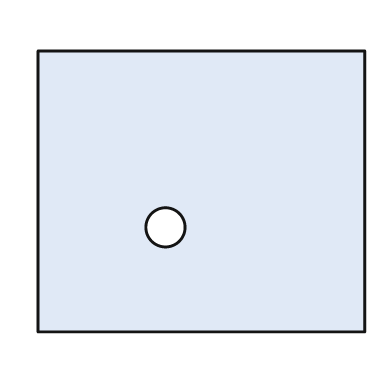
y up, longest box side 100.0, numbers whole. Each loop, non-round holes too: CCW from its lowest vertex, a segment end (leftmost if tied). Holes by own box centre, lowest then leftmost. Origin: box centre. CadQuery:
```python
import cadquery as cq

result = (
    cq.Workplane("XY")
    .moveTo(-50.0, -43.0)
    .lineTo(50.0, -43.0)
    .lineTo(50.0, 43.0)
    .lineTo(-50.0, 43.0)
    .close()
    .moveTo(-11.0, -11.0)
    .circle(6.0)
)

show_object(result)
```